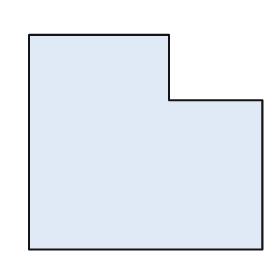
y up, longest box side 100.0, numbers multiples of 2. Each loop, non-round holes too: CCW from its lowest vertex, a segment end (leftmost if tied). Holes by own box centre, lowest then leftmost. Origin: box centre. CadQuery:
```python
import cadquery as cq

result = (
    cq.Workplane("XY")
    .moveTo(-50.0, -46.0)
    .lineTo(50.0, -46.0)
    .lineTo(50.0, 18.0)
    .lineTo(10.0, 18.0)
    .lineTo(10.0, 46.0)
    .lineTo(-50.0, 46.0)
    .close()
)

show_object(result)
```